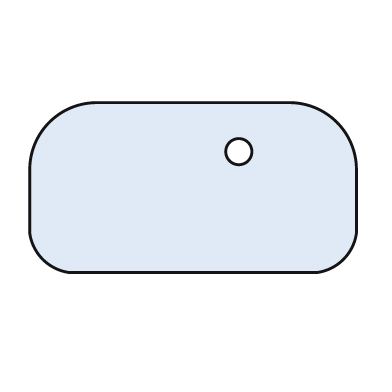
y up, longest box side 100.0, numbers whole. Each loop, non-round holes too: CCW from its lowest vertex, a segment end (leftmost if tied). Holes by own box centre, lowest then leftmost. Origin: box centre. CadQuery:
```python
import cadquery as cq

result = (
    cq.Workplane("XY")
    .moveTo(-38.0, -26.0)
    .lineTo(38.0, -26.0)
    .threePointArc((46.0, -22.0), (50.0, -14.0))
    .lineTo(50.0, 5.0)
    .threePointArc((44.0, 20.0), (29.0, 26.0))
    .lineTo(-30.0, 26.0)
    .threePointArc((-44.0, 20.0), (-50.0, 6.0))
    .lineTo(-50.0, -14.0)
    .threePointArc((-46.0, -22.0), (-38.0, -26.0))
    .close()
    .moveTo(14.0, 11.0)
    .circle(4.0)
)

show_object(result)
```